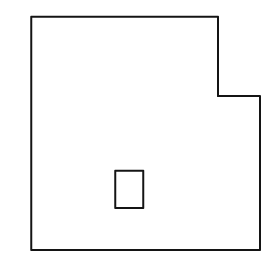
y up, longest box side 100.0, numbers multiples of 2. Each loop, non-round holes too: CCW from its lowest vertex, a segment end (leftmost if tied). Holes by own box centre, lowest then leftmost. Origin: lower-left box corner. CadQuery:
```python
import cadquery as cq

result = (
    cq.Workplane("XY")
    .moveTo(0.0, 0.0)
    .lineTo(98.0, 0.0)
    .lineTo(98.0, 66.0)
    .lineTo(80.0, 66.0)
    .lineTo(80.0, 100.0)
    .lineTo(0.0, 100.0)
    .close()
    .moveTo(36.0, 18.0)
    .lineTo(48.0, 18.0)
    .lineTo(48.0, 34.0)
    .lineTo(36.0, 34.0)
    .close()
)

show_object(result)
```